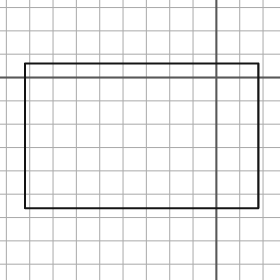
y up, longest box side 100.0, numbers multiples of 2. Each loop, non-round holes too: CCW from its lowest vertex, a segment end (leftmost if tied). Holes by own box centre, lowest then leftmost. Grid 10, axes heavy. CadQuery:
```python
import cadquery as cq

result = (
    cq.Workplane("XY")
    .moveTo(-82.0, -56.0)
    .lineTo(18.0, -56.0)
    .lineTo(18.0, 6.0)
    .lineTo(-82.0, 6.0)
    .close()
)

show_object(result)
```